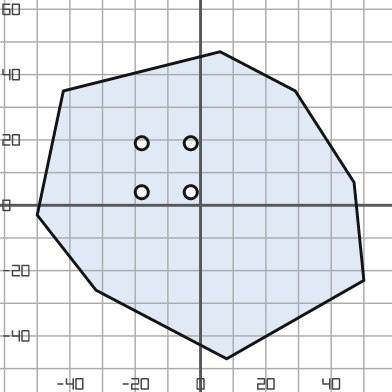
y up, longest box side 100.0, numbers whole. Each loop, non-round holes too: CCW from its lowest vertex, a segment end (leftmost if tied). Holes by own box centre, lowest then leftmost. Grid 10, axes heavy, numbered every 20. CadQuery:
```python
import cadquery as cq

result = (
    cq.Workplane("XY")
    .moveTo(8.0, -47.0)
    .lineTo(50.0, -23.0)
    .lineTo(47.0, 7.0)
    .lineTo(29.0, 35.0)
    .lineTo(6.0, 47.0)
    .lineTo(-42.0, 35.0)
    .lineTo(-50.0, -3.0)
    .lineTo(-32.0, -26.0)
    .close()
    .moveTo(-18.0, 4.0)
    .circle(2.0)
    .moveTo(-3.0, 4.0)
    .circle(2.0)
    .moveTo(-18.0, 19.0)
    .circle(2.0)
    .moveTo(-3.0, 19.0)
    .circle(2.0)
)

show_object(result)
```